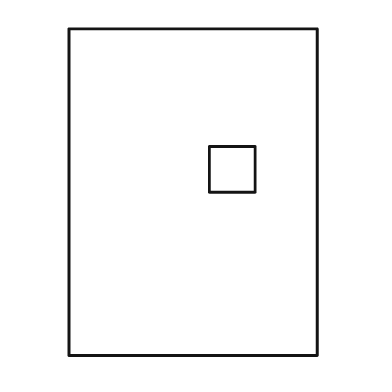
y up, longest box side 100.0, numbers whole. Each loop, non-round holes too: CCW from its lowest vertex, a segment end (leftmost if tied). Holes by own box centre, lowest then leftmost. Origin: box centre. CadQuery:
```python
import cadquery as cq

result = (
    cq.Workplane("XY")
    .moveTo(-38.0, -50.0)
    .lineTo(38.0, -50.0)
    .lineTo(38.0, 50.0)
    .lineTo(-38.0, 50.0)
    .close()
    .moveTo(5.0, 0.0)
    .lineTo(19.0, 0.0)
    .lineTo(19.0, 14.0)
    .lineTo(5.0, 14.0)
    .close()
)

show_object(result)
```